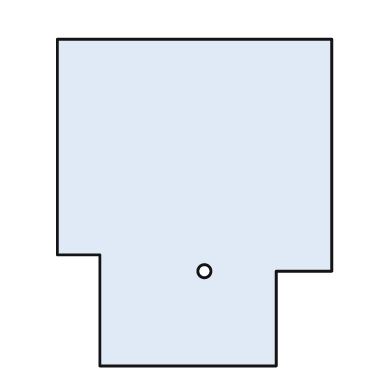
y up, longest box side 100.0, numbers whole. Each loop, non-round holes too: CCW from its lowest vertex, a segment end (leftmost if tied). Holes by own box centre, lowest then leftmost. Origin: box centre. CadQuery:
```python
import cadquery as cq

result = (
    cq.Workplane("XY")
    .moveTo(-29.0, -50.0)
    .lineTo(25.0, -50.0)
    .lineTo(25.0, -21.0)
    .lineTo(42.0, -21.0)
    .lineTo(42.0, 50.0)
    .lineTo(-42.0, 50.0)
    .lineTo(-42.0, -16.0)
    .lineTo(-29.0, -16.0)
    .close()
    .moveTo(3.0, -21.0)
    .circle(2.0)
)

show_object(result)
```